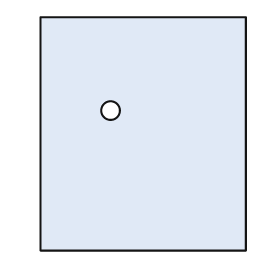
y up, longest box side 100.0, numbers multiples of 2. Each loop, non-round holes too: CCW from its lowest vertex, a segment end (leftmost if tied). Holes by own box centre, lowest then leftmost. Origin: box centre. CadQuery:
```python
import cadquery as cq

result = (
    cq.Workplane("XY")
    .moveTo(-44.0, -50.0)
    .lineTo(44.0, -50.0)
    .lineTo(44.0, 50.0)
    .lineTo(-44.0, 50.0)
    .close()
    .moveTo(-14.0, 10.0)
    .circle(4.0)
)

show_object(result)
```